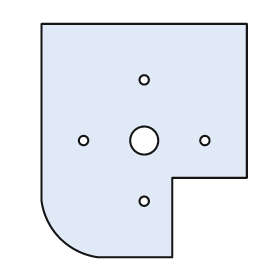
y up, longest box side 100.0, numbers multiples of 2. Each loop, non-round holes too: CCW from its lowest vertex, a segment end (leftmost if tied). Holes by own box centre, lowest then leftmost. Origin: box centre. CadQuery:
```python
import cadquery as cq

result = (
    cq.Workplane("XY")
    .moveTo(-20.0, -50.0)
    .lineTo(12.0, -50.0)
    .lineTo(12.0, -16.0)
    .lineTo(44.0, -16.0)
    .lineTo(44.0, 50.0)
    .lineTo(-44.0, 50.0)
    .lineTo(-44.0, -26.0)
    .threePointArc((-36.0, -42.0), (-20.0, -50.0))
    .close()
    .moveTo(0.0, -26.0)
    .circle(2.0)
    .moveTo(-26.0, 0.0)
    .circle(2.0)
    .moveTo(0.0, 0.0)
    .circle(6.0)
    .moveTo(26.0, 0.0)
    .circle(2.0)
    .moveTo(0.0, 26.0)
    .circle(2.0)
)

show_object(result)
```